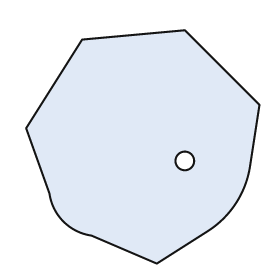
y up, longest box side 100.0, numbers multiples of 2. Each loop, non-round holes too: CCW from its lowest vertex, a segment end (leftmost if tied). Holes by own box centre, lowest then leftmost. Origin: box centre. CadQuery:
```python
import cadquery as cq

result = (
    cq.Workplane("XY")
    .moveTo(6.0, -50.0)
    .lineTo(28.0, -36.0)
    .threePointArc((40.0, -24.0), (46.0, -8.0))
    .lineTo(50.0, 18.0)
    .lineTo(18.0, 50.0)
    .lineTo(-26.0, 46.0)
    .lineTo(-50.0, 8.0)
    .lineTo(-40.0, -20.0)
    .threePointArc((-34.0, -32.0), (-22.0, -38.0))
    .close()
    .moveTo(18.0, -6.0)
    .circle(4.0)
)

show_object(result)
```